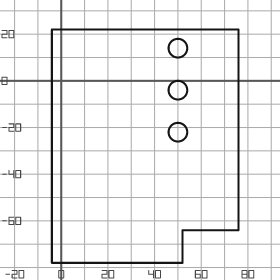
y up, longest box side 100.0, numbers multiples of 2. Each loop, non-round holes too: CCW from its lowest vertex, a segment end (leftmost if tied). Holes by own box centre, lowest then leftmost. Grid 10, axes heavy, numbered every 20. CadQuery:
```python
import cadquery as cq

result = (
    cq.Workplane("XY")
    .moveTo(-4.0, -78.0)
    .lineTo(52.0, -78.0)
    .lineTo(52.0, -64.0)
    .lineTo(76.0, -64.0)
    .lineTo(76.0, 22.0)
    .lineTo(-4.0, 22.0)
    .close()
    .moveTo(50.0, -22.0)
    .circle(4.0)
    .moveTo(50.0, -4.0)
    .circle(4.0)
    .moveTo(50.0, 14.0)
    .circle(4.0)
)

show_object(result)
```